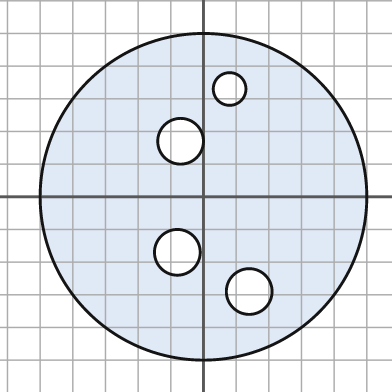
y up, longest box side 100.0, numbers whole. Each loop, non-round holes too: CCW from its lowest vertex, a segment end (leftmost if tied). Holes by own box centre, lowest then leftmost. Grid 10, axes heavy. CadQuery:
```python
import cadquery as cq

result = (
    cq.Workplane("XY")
    .moveTo(0.0, 0.0)
    .circle(50.0)
    .moveTo(14.0, -29.0)
    .circle(7.0)
    .moveTo(-8.0, -17.0)
    .circle(7.0)
    .moveTo(-7.0, 17.0)
    .circle(7.0)
    .moveTo(8.0, 33.0)
    .circle(5.0)
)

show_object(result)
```